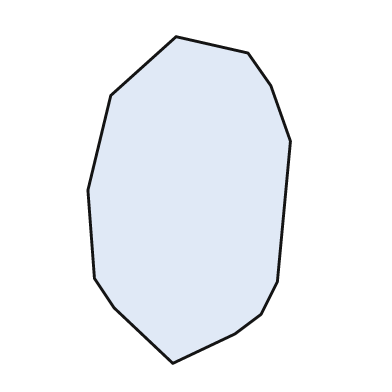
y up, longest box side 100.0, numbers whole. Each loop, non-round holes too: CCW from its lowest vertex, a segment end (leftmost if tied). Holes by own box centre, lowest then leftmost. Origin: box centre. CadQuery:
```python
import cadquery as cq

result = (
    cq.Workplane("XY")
    .moveTo(-5.0, -50.0)
    .lineTo(14.0, -41.0)
    .lineTo(22.0, -35.0)
    .lineTo(27.0, -25.0)
    .lineTo(31.0, 18.0)
    .lineTo(25.0, 35.0)
    .lineTo(18.0, 45.0)
    .lineTo(-4.0, 50.0)
    .lineTo(-24.0, 32.0)
    .lineTo(-31.0, 3.0)
    .lineTo(-29.0, -24.0)
    .lineTo(-23.0, -33.0)
    .close()
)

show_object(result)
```